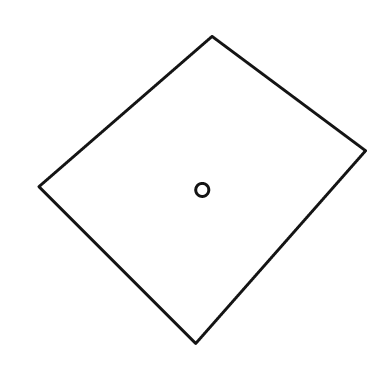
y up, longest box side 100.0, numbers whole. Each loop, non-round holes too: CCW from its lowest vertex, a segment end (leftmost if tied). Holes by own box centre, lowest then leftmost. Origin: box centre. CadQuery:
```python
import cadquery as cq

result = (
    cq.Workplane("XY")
    .moveTo(-2.0, -47.0)
    .lineTo(50.0, 12.0)
    .lineTo(3.0, 47.0)
    .lineTo(-50.0, 1.0)
    .close()
    .moveTo(0.0, 0.0)
    .circle(2.0)
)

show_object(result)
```